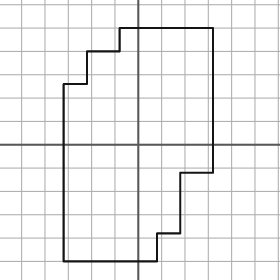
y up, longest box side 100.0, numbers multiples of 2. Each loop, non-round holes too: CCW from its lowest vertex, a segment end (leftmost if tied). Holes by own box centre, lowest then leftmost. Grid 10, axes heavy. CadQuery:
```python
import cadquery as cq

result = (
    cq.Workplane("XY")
    .moveTo(-32.0, -50.0)
    .lineTo(8.0, -50.0)
    .lineTo(8.0, -38.0)
    .lineTo(18.0, -38.0)
    .lineTo(18.0, -12.0)
    .lineTo(32.0, -12.0)
    .lineTo(32.0, 50.0)
    .lineTo(-8.0, 50.0)
    .lineTo(-8.0, 40.0)
    .lineTo(-22.0, 40.0)
    .lineTo(-22.0, 26.0)
    .lineTo(-32.0, 26.0)
    .close()
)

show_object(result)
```